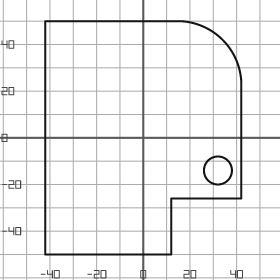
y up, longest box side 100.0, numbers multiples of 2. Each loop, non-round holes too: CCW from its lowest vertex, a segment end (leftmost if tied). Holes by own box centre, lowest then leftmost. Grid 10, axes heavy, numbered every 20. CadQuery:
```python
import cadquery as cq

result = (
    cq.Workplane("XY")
    .moveTo(-42.0, -50.0)
    .lineTo(12.0, -50.0)
    .lineTo(12.0, -26.0)
    .lineTo(42.0, -26.0)
    .lineTo(42.0, 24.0)
    .threePointArc((34.0, 42.0), (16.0, 50.0))
    .lineTo(-42.0, 50.0)
    .close()
    .moveTo(32.0, -14.0)
    .circle(6.0)
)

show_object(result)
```